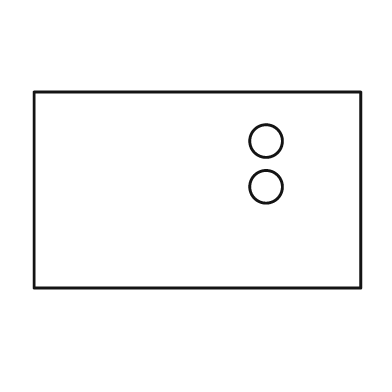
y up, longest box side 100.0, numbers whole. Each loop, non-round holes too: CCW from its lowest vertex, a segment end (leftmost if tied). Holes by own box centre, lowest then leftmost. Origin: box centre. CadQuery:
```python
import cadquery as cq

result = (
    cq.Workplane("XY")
    .moveTo(-50.0, -30.0)
    .lineTo(50.0, -30.0)
    .lineTo(50.0, 30.0)
    .lineTo(-50.0, 30.0)
    .close()
    .moveTo(21.0, 1.0)
    .circle(5.0)
    .moveTo(21.0, 15.0)
    .circle(5.0)
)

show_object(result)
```